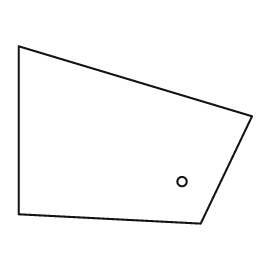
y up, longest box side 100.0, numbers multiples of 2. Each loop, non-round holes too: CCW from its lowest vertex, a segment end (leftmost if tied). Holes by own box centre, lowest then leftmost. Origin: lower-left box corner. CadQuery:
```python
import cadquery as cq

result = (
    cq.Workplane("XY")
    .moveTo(78.0, 0.0)
    .lineTo(100.0, 46.0)
    .lineTo(0.0, 76.0)
    .lineTo(0.0, 4.0)
    .close()
    .moveTo(70.0, 18.0)
    .circle(2.0)
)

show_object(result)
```